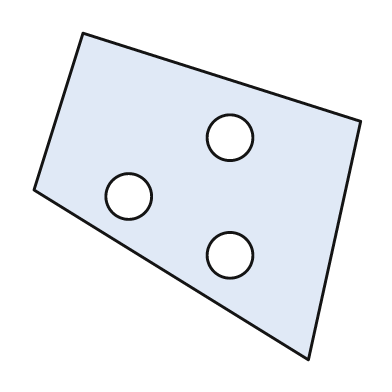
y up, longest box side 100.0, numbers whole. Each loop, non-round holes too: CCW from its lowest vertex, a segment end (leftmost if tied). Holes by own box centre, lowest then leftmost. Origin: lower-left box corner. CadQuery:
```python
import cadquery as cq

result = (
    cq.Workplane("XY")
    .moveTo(84.0, 0.0)
    .lineTo(100.0, 73.0)
    .lineTo(15.0, 100.0)
    .lineTo(0.0, 52.0)
    .close()
    .moveTo(60.0, 32.0)
    .circle(7.0)
    .moveTo(29.0, 50.0)
    .circle(7.0)
    .moveTo(60.0, 68.0)
    .circle(7.0)
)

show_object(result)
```